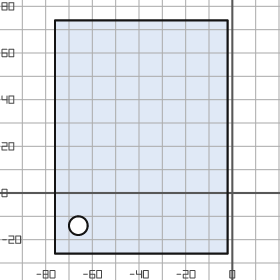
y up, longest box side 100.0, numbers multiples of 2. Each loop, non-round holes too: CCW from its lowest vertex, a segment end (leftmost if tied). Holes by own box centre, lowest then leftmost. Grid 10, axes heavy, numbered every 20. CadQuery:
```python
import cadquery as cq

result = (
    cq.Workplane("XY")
    .moveTo(-76.0, -26.0)
    .lineTo(-2.0, -26.0)
    .lineTo(-2.0, 74.0)
    .lineTo(-76.0, 74.0)
    .close()
    .moveTo(-66.0, -14.0)
    .circle(4.0)
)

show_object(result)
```